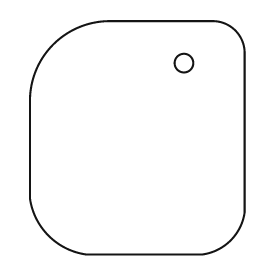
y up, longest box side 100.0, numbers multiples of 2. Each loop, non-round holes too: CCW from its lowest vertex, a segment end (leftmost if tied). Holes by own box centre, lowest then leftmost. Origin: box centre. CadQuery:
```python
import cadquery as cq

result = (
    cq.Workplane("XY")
    .moveTo(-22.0, -50.0)
    .lineTo(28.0, -50.0)
    .threePointArc((40.0, -44.0), (46.0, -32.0))
    .lineTo(46.0, 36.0)
    .threePointArc((42.0, 46.0), (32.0, 50.0))
    .lineTo(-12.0, 50.0)
    .threePointArc((-36.0, 40.0), (-46.0, 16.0))
    .lineTo(-46.0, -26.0)
    .threePointArc((-38.0, -42.0), (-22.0, -50.0))
    .close()
    .moveTo(20.0, 32.0)
    .circle(4.0)
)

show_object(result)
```